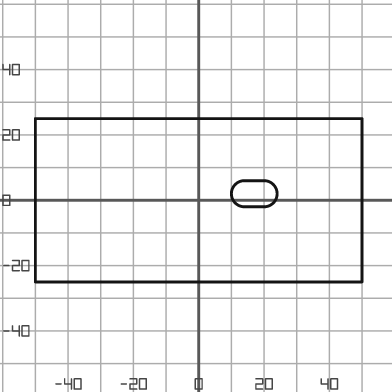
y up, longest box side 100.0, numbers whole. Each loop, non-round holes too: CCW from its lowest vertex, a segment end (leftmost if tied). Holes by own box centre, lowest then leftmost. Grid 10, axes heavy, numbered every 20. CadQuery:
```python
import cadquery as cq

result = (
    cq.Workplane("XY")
    .moveTo(-50.0, -25.0)
    .lineTo(50.0, -25.0)
    .lineTo(50.0, 25.0)
    .lineTo(-50.0, 25.0)
    .close()
    .moveTo(14.0, -2.0)
    .lineTo(20.0, -2.0)
    .threePointArc((24.0, 2.0), (20.0, 6.0))
    .lineTo(14.0, 6.0)
    .threePointArc((10.0, 2.0), (14.0, -2.0))
    .close()
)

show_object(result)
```